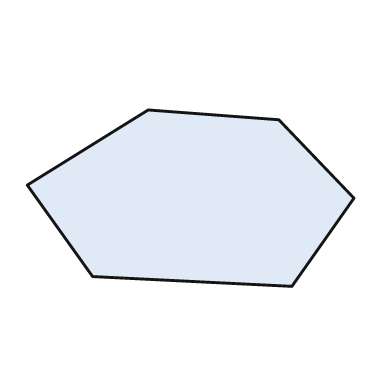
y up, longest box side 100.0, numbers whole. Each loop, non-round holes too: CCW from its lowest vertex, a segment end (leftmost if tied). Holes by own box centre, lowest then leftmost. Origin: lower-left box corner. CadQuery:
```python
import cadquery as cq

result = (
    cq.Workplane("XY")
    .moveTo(81.0, 0.0)
    .lineTo(100.0, 27.0)
    .lineTo(77.0, 51.0)
    .lineTo(37.0, 54.0)
    .lineTo(0.0, 31.0)
    .lineTo(20.0, 3.0)
    .close()
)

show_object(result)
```